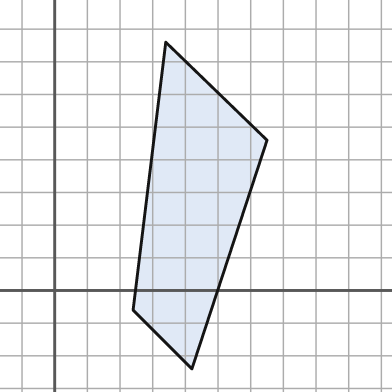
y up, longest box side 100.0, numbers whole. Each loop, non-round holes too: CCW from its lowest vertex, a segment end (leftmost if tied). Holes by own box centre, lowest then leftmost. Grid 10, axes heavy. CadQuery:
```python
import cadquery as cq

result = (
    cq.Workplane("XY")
    .moveTo(42.0, -24.0)
    .lineTo(65.0, 46.0)
    .lineTo(34.0, 76.0)
    .lineTo(24.0, -6.0)
    .close()
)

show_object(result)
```